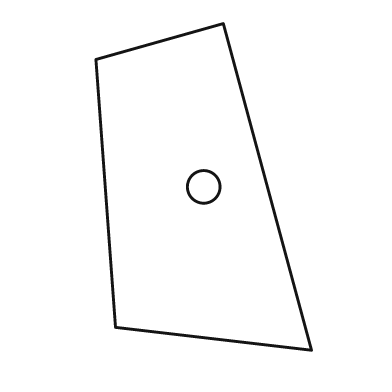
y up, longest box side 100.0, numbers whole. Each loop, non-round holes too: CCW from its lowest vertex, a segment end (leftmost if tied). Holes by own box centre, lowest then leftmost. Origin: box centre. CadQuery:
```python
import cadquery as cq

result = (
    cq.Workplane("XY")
    .moveTo(33.0, -50.0)
    .lineTo(6.0, 50.0)
    .lineTo(-33.0, 39.0)
    .lineTo(-27.0, -43.0)
    .close()
    .moveTo(0.0, 0.0)
    .circle(5.0)
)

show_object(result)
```